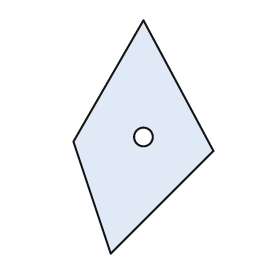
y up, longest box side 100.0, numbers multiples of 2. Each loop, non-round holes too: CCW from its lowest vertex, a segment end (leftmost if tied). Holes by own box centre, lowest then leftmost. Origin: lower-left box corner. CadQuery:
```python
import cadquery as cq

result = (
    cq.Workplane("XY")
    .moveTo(16.0, 0.0)
    .lineTo(60.0, 44.0)
    .lineTo(30.0, 100.0)
    .lineTo(0.0, 48.0)
    .close()
    .moveTo(30.0, 50.0)
    .circle(4.0)
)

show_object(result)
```